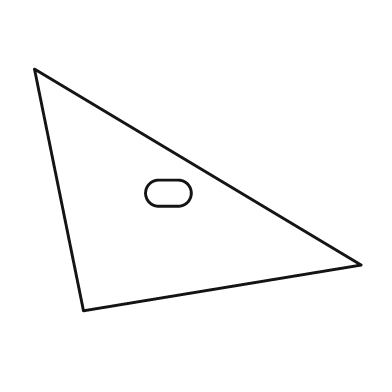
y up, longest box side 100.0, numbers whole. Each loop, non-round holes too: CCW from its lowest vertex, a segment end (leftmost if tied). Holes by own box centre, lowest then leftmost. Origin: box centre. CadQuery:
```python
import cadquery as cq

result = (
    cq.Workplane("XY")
    .moveTo(-35.0, -37.0)
    .lineTo(50.0, -23.0)
    .lineTo(-50.0, 37.0)
    .close()
    .moveTo(-12.0, -5.0)
    .lineTo(-6.0, -5.0)
    .threePointArc((-2.0, -1.0), (-6.0, 3.0))
    .lineTo(-12.0, 3.0)
    .threePointArc((-16.0, -1.0), (-12.0, -5.0))
    .close()
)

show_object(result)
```